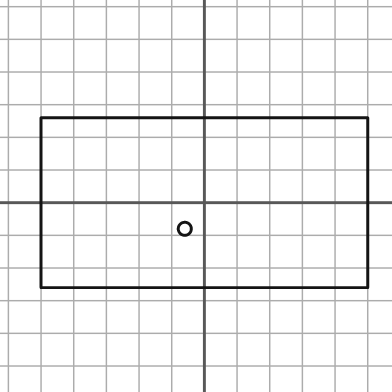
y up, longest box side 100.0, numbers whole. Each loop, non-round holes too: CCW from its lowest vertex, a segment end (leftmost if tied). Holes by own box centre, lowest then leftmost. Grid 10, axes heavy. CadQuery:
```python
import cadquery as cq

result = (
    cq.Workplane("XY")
    .moveTo(-50.0, -26.0)
    .lineTo(50.0, -26.0)
    .lineTo(50.0, 26.0)
    .lineTo(-50.0, 26.0)
    .close()
    .moveTo(-6.0, -8.0)
    .circle(2.0)
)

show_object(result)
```